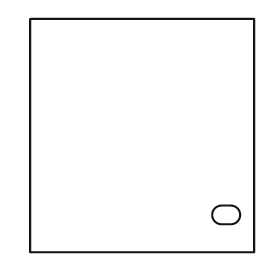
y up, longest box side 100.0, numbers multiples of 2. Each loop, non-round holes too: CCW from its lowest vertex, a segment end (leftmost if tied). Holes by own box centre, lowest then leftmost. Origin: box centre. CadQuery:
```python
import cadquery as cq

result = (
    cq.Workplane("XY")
    .moveTo(-48.0, -50.0)
    .lineTo(48.0, -50.0)
    .lineTo(48.0, 50.0)
    .lineTo(-48.0, 50.0)
    .close()
    .moveTo(34.0, -38.0)
    .lineTo(38.0, -38.0)
    .threePointArc((42.0, -34.0), (38.0, -30.0))
    .lineTo(34.0, -30.0)
    .threePointArc((30.0, -34.0), (34.0, -38.0))
    .close()
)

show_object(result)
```